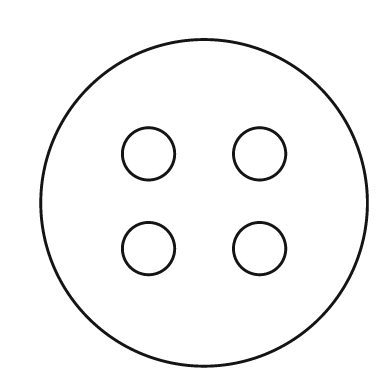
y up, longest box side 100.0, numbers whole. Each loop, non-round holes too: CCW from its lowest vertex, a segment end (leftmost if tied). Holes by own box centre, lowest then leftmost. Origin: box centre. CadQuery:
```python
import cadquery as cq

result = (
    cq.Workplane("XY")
    .moveTo(0.0, 0.0)
    .circle(50.0)
    .moveTo(-17.0, -14.0)
    .circle(8.0)
    .moveTo(17.0, -14.0)
    .circle(8.0)
    .moveTo(-17.0, 15.0)
    .circle(8.0)
    .moveTo(17.0, 15.0)
    .circle(8.0)
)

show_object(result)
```